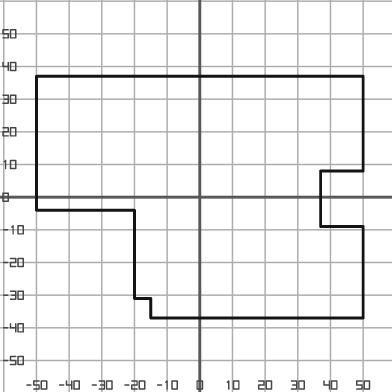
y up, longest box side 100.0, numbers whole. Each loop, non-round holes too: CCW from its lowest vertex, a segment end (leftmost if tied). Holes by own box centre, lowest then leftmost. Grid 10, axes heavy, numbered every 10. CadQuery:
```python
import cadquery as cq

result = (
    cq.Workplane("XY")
    .moveTo(-15.0, -37.0)
    .lineTo(50.0, -37.0)
    .lineTo(50.0, -9.0)
    .lineTo(37.0, -9.0)
    .lineTo(37.0, 8.0)
    .lineTo(50.0, 8.0)
    .lineTo(50.0, 37.0)
    .lineTo(-50.0, 37.0)
    .lineTo(-50.0, -4.0)
    .lineTo(-20.0, -4.0)
    .lineTo(-20.0, -31.0)
    .lineTo(-15.0, -31.0)
    .close()
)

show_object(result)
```